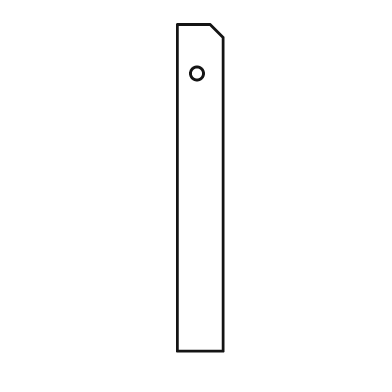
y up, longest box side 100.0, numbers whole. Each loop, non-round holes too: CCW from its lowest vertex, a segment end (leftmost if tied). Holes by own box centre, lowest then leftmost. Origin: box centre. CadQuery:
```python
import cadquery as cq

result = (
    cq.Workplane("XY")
    .moveTo(-7.0, -50.0)
    .lineTo(7.0, -50.0)
    .lineTo(7.0, 46.0)
    .lineTo(3.0, 50.0)
    .lineTo(-7.0, 50.0)
    .close()
    .moveTo(-1.0, 35.0)
    .circle(2.0)
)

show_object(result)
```